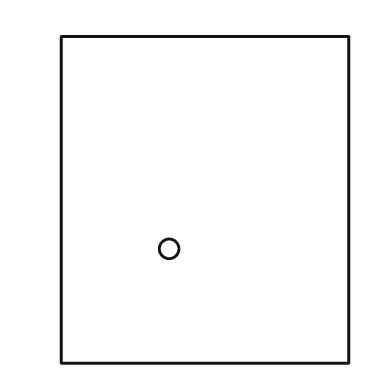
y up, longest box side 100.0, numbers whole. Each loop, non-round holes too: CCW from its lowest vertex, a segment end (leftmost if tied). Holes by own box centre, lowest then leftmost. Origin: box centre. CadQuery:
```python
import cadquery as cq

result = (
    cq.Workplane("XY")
    .moveTo(-44.0, -50.0)
    .lineTo(44.0, -50.0)
    .lineTo(44.0, 50.0)
    .lineTo(-44.0, 50.0)
    .close()
    .moveTo(-11.0, -15.0)
    .circle(3.0)
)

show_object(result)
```